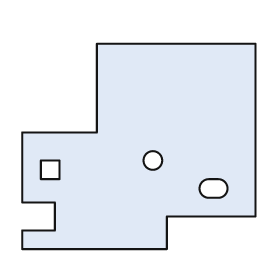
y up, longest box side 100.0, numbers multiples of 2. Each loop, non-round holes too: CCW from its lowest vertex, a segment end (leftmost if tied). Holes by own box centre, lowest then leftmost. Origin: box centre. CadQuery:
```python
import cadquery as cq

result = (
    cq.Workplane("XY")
    .moveTo(-50.0, -44.0)
    .lineTo(12.0, -44.0)
    .lineTo(12.0, -30.0)
    .lineTo(50.0, -30.0)
    .lineTo(50.0, 44.0)
    .lineTo(-18.0, 44.0)
    .lineTo(-18.0, 6.0)
    .lineTo(-50.0, 6.0)
    .lineTo(-50.0, -24.0)
    .lineTo(-36.0, -24.0)
    .lineTo(-36.0, -36.0)
    .lineTo(-50.0, -36.0)
    .close()
    .moveTo(30.0, -22.0)
    .lineTo(34.0, -22.0)
    .threePointArc((38.0, -18.0), (34.0, -14.0))
    .lineTo(30.0, -14.0)
    .threePointArc((26.0, -18.0), (30.0, -22.0))
    .close()
    .moveTo(-42.0, -14.0)
    .lineTo(-34.0, -14.0)
    .lineTo(-34.0, -6.0)
    .lineTo(-42.0, -6.0)
    .close()
    .moveTo(6.0, -6.0)
    .circle(4.0)
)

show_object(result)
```